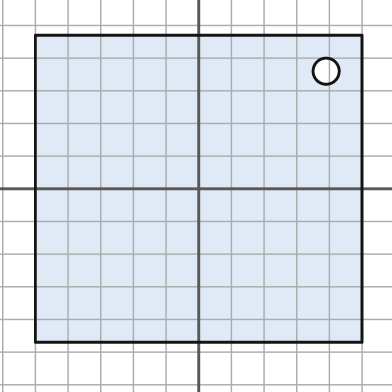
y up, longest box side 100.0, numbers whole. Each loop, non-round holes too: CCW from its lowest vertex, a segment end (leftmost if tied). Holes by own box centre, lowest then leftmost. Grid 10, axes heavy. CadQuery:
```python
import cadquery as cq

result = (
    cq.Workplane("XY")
    .moveTo(-50.0, -47.0)
    .lineTo(50.0, -47.0)
    .lineTo(50.0, 47.0)
    .lineTo(-50.0, 47.0)
    .close()
    .moveTo(39.0, 36.0)
    .circle(4.0)
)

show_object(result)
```